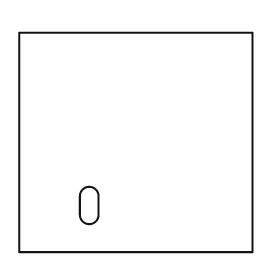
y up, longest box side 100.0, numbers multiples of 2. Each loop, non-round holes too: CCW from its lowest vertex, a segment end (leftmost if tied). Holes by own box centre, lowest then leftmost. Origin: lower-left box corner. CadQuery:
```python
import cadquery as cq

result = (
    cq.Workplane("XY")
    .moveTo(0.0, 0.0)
    .lineTo(100.0, 0.0)
    .lineTo(100.0, 94.0)
    .lineTo(0.0, 94.0)
    .close()
    .moveTo(26.0, 16.0)
    .threePointArc((30.0, 12.0), (34.0, 16.0))
    .lineTo(34.0, 24.0)
    .threePointArc((30.0, 28.0), (26.0, 24.0))
    .close()
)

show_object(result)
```